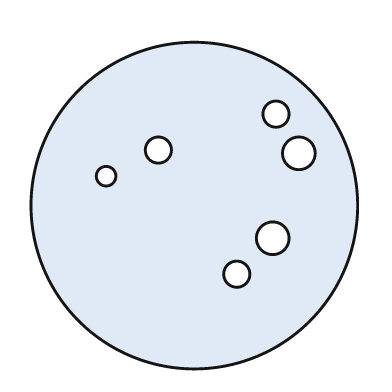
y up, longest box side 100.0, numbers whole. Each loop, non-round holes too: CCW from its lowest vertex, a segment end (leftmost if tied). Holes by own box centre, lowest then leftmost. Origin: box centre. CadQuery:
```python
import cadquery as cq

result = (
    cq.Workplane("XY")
    .moveTo(0.0, 0.0)
    .circle(50.0)
    .moveTo(13.0, -21.0)
    .circle(4.0)
    .moveTo(24.0, -10.0)
    .circle(5.0)
    .moveTo(-27.0, 9.0)
    .circle(3.0)
    .moveTo(32.0, 16.0)
    .circle(5.0)
    .moveTo(-11.0, 17.0)
    .circle(4.0)
    .moveTo(25.0, 28.0)
    .circle(4.0)
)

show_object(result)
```